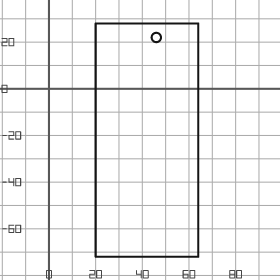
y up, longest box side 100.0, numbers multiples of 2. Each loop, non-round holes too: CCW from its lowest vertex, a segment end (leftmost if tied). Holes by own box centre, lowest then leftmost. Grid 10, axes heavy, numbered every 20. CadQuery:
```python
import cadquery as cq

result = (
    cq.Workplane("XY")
    .moveTo(20.0, -72.0)
    .lineTo(64.0, -72.0)
    .lineTo(64.0, 28.0)
    .lineTo(20.0, 28.0)
    .close()
    .moveTo(46.0, 22.0)
    .circle(2.0)
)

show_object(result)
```